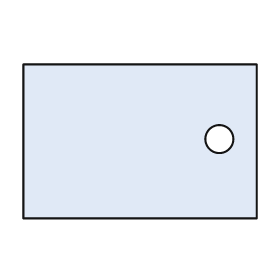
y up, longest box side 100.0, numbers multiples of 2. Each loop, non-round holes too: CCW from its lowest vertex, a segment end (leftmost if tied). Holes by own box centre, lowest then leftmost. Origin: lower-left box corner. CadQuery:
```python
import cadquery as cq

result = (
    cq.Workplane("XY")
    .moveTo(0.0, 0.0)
    .lineTo(100.0, 0.0)
    .lineTo(100.0, 66.0)
    .lineTo(0.0, 66.0)
    .close()
    .moveTo(84.0, 34.0)
    .circle(6.0)
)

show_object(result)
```